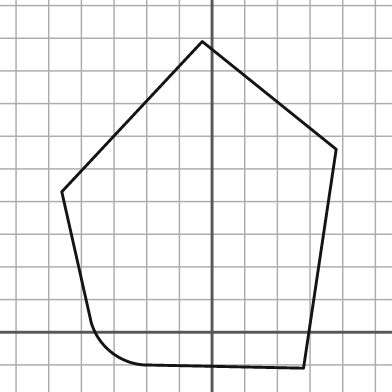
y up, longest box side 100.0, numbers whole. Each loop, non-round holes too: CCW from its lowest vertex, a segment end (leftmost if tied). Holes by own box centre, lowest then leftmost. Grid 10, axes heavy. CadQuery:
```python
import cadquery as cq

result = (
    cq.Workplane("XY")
    .moveTo(28.0, -11.0)
    .lineTo(38.0, 56.0)
    .lineTo(-3.0, 89.0)
    .lineTo(-46.0, 43.0)
    .lineTo(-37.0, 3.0)
    .threePointArc((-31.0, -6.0), (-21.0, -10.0))
    .close()
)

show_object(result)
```